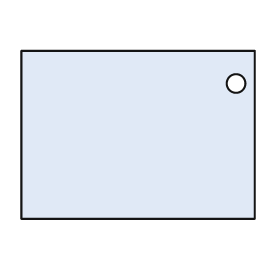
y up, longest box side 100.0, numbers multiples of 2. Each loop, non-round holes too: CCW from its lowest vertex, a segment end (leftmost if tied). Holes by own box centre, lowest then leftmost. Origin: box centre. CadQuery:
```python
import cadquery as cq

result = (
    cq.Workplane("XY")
    .moveTo(-50.0, -36.0)
    .lineTo(50.0, -36.0)
    .lineTo(50.0, 36.0)
    .lineTo(-50.0, 36.0)
    .close()
    .moveTo(42.0, 22.0)
    .circle(4.0)
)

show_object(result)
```